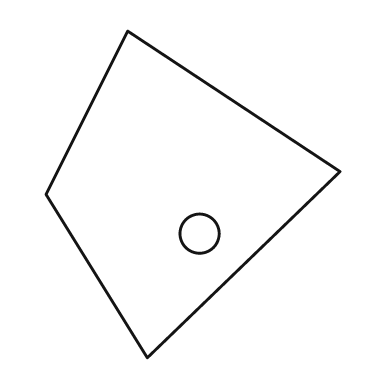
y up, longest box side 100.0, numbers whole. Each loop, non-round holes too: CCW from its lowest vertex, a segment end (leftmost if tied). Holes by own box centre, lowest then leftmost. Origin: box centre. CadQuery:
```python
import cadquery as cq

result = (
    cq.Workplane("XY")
    .moveTo(-14.0, -50.0)
    .lineTo(45.0, 7.0)
    .lineTo(-20.0, 50.0)
    .lineTo(-45.0, 0.0)
    .close()
    .moveTo(2.0, -12.0)
    .circle(6.0)
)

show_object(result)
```